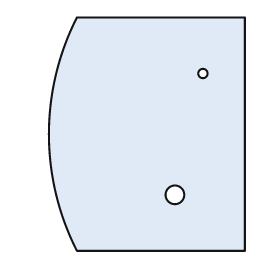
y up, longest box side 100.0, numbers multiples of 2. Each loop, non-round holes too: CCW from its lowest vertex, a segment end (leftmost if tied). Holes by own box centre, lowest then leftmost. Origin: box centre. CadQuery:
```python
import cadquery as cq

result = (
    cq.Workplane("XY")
    .moveTo(-30.0, -50.0)
    .lineTo(42.0, -50.0)
    .lineTo(42.0, 50.0)
    .lineTo(-30.0, 50.0)
    .threePointArc((-42.0, 0.0), (-30.0, -50.0))
    .close()
    .moveTo(12.0, -26.0)
    .circle(4.0)
    .moveTo(24.0, 26.0)
    .circle(2.0)
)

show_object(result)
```